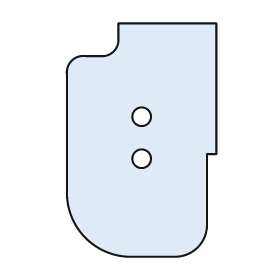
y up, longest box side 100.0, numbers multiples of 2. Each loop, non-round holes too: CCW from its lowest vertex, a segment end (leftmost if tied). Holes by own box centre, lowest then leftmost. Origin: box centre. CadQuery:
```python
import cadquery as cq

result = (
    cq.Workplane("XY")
    .moveTo(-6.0, -50.0)
    .lineTo(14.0, -50.0)
    .threePointArc((24.0, -46.0), (28.0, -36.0))
    .lineTo(28.0, -6.0)
    .lineTo(32.0, -6.0)
    .lineTo(32.0, 50.0)
    .lineTo(-10.0, 50.0)
    .lineTo(-10.0, 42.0)
    .threePointArc((-12.0, 38.0), (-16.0, 36.0))
    .lineTo(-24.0, 36.0)
    .threePointArc((-30.0, 34.0), (-32.0, 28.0))
    .lineTo(-32.0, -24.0)
    .threePointArc((-24.0, -42.0), (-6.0, -50.0))
    .close()
    .moveTo(0.0, -8.0)
    .circle(4.0)
    .moveTo(0.0, 10.0)
    .circle(4.0)
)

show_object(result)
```